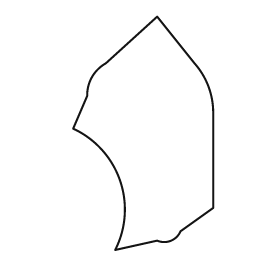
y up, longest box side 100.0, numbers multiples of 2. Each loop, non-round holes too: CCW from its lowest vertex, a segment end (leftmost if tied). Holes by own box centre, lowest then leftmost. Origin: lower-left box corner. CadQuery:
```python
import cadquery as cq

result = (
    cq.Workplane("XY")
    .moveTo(18.0, 0.0)
    .lineTo(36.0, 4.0)
    .threePointArc((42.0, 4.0), (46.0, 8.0))
    .lineTo(60.0, 18.0)
    .lineTo(60.0, 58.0)
    .threePointArc((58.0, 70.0), (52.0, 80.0))
    .lineTo(36.0, 100.0)
    .lineTo(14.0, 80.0)
    .threePointArc((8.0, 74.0), (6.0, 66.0))
    .lineTo(0.0, 52.0)
    .threePointArc((20.0, 30.0), (18.0, 0.0))
    .close()
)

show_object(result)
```